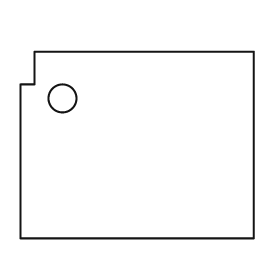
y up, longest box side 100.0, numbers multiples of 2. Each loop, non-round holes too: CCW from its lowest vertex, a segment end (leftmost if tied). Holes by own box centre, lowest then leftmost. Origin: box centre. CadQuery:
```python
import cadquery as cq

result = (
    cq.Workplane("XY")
    .moveTo(-50.0, -40.0)
    .lineTo(50.0, -40.0)
    .lineTo(50.0, 40.0)
    .lineTo(-44.0, 40.0)
    .lineTo(-44.0, 26.0)
    .lineTo(-50.0, 26.0)
    .close()
    .moveTo(-32.0, 20.0)
    .circle(6.0)
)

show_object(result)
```